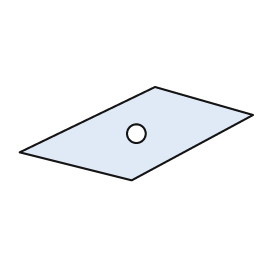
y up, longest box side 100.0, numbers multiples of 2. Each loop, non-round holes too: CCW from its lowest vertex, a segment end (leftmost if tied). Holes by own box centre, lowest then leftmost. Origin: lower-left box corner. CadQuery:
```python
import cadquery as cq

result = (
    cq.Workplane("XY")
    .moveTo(48.0, 0.0)
    .lineTo(100.0, 28.0)
    .lineTo(58.0, 40.0)
    .lineTo(0.0, 12.0)
    .close()
    .moveTo(50.0, 20.0)
    .circle(4.0)
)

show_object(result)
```